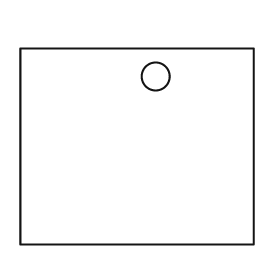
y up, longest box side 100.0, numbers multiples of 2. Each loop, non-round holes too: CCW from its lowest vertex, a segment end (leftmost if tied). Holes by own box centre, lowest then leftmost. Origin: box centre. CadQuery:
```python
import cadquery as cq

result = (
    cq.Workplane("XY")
    .moveTo(-50.0, -42.0)
    .lineTo(50.0, -42.0)
    .lineTo(50.0, 42.0)
    .lineTo(-50.0, 42.0)
    .close()
    .moveTo(8.0, 30.0)
    .circle(6.0)
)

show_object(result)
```